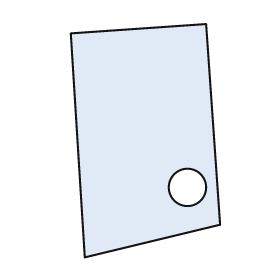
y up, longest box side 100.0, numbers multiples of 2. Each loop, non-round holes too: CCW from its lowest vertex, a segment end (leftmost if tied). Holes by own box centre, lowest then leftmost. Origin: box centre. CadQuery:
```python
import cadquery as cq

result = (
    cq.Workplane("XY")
    .moveTo(-26.0, -50.0)
    .lineTo(32.0, -36.0)
    .lineTo(26.0, 50.0)
    .lineTo(-32.0, 46.0)
    .close()
    .moveTo(18.0, -20.0)
    .circle(8.0)
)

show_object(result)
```